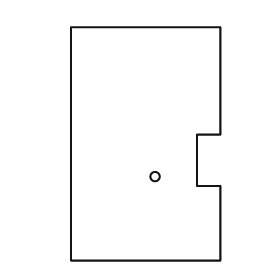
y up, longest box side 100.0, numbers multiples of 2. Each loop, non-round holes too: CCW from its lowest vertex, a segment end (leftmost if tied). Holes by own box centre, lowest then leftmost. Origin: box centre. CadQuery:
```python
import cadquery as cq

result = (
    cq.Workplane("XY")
    .moveTo(-32.0, -50.0)
    .lineTo(32.0, -50.0)
    .lineTo(32.0, -18.0)
    .lineTo(22.0, -18.0)
    .lineTo(22.0, 4.0)
    .lineTo(32.0, 4.0)
    .lineTo(32.0, 50.0)
    .lineTo(-32.0, 50.0)
    .close()
    .moveTo(4.0, -14.0)
    .circle(2.0)
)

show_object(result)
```